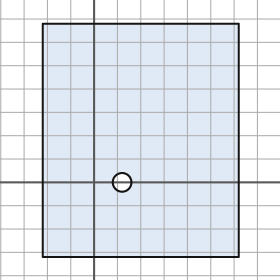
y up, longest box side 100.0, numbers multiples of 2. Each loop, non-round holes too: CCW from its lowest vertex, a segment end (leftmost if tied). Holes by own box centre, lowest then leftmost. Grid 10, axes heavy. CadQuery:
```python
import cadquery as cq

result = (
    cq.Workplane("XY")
    .moveTo(-22.0, -32.0)
    .lineTo(62.0, -32.0)
    .lineTo(62.0, 68.0)
    .lineTo(-22.0, 68.0)
    .close()
    .moveTo(12.0, 0.0)
    .circle(4.0)
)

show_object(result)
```